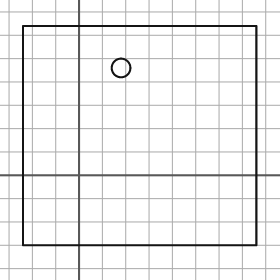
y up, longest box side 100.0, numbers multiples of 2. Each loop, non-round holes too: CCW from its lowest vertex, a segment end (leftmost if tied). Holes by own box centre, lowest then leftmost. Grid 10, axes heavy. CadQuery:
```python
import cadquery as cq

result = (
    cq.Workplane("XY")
    .moveTo(-24.0, -30.0)
    .lineTo(76.0, -30.0)
    .lineTo(76.0, 64.0)
    .lineTo(-24.0, 64.0)
    .close()
    .moveTo(18.0, 46.0)
    .circle(4.0)
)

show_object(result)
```